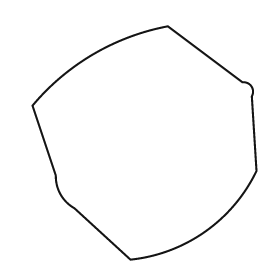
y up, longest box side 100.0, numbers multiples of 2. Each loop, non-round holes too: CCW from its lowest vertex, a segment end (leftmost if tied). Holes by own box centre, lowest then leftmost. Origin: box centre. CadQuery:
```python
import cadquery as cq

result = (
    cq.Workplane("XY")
    .moveTo(-6.0, -50.0)
    .threePointArc((26.0, -38.0), (48.0, -12.0))
    .lineTo(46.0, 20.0)
    .threePointArc((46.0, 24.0), (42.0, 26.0))
    .lineTo(10.0, 50.0)
    .threePointArc((-22.0, 38.0), (-48.0, 16.0))
    .lineTo(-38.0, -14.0)
    .threePointArc((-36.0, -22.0), (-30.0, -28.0))
    .close()
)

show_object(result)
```